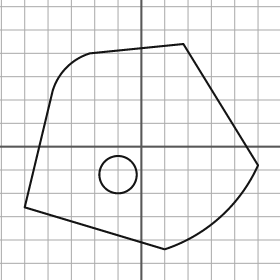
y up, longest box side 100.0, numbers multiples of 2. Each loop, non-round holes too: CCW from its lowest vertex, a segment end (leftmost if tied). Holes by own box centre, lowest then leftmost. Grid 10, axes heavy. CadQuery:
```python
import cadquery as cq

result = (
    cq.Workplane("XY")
    .moveTo(10.0, -44.0)
    .threePointArc((34.0, -30.0), (50.0, -8.0))
    .lineTo(18.0, 44.0)
    .lineTo(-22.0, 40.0)
    .threePointArc((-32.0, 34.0), (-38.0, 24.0))
    .lineTo(-50.0, -26.0)
    .close()
    .moveTo(-10.0, -12.0)
    .circle(8.0)
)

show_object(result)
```